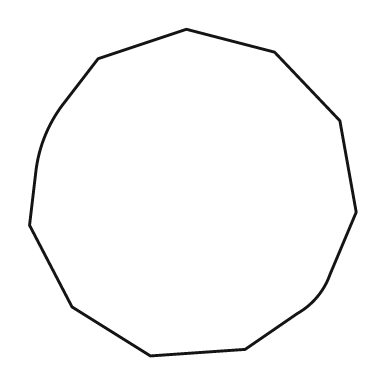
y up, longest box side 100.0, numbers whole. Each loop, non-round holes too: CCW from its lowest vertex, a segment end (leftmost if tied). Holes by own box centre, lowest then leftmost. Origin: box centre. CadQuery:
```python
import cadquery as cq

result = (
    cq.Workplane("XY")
    .moveTo(-13.0, -50.0)
    .lineTo(16.0, -48.0)
    .lineTo(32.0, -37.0)
    .threePointArc((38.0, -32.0), (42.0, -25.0))
    .lineTo(50.0, -6.0)
    .lineTo(45.0, 22.0)
    .lineTo(25.0, 43.0)
    .lineTo(-2.0, 50.0)
    .lineTo(-29.0, 41.0)
    .lineTo(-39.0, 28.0)
    .threePointArc((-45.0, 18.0), (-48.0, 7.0))
    .lineTo(-50.0, -10.0)
    .lineTo(-37.0, -35.0)
    .close()
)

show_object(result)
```